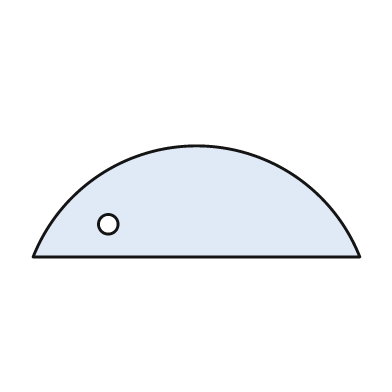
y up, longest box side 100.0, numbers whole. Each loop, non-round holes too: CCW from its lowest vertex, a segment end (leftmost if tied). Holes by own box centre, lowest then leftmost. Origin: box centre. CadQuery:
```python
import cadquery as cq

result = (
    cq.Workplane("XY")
    .moveTo(-50.0, -17.0)
    .lineTo(50.0, -17.0)
    .threePointArc((0.0, 17.0), (-50.0, -17.0))
    .close()
    .moveTo(-27.0, -7.0)
    .circle(3.0)
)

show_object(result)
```